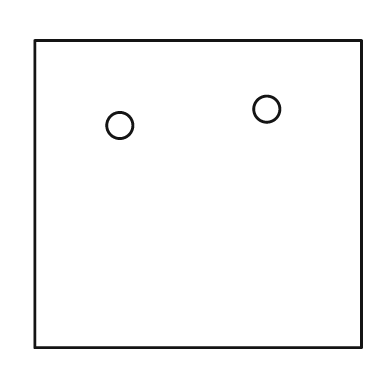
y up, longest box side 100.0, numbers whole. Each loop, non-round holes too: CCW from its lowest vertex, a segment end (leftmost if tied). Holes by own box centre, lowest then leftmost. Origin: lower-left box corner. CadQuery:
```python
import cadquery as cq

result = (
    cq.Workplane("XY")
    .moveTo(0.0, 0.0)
    .lineTo(100.0, 0.0)
    .lineTo(100.0, 94.0)
    .lineTo(0.0, 94.0)
    .close()
    .moveTo(26.0, 68.0)
    .circle(4.0)
    .moveTo(71.0, 73.0)
    .circle(4.0)
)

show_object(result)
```